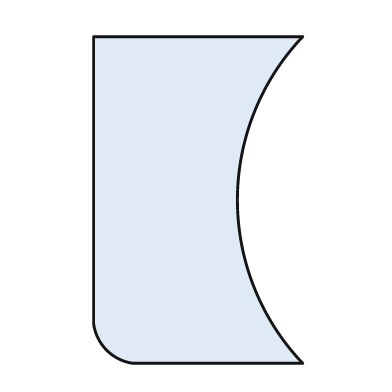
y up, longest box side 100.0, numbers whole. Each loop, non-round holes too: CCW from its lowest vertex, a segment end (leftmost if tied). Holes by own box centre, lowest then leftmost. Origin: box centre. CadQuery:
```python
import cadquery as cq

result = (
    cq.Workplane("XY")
    .moveTo(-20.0, -50.0)
    .lineTo(32.0, -50.0)
    .threePointArc((12.0, 0.0), (32.0, 50.0))
    .lineTo(-32.0, 50.0)
    .lineTo(-32.0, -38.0)
    .threePointArc((-28.0, -46.0), (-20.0, -50.0))
    .close()
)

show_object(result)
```